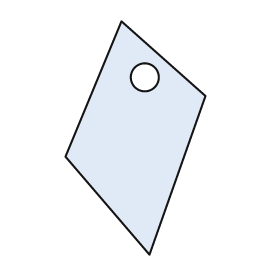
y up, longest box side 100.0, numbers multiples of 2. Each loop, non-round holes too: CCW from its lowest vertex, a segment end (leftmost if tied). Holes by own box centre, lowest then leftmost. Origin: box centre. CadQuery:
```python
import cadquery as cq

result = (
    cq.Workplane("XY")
    .moveTo(6.0, -50.0)
    .lineTo(30.0, 18.0)
    .lineTo(-6.0, 50.0)
    .lineTo(-30.0, -8.0)
    .close()
    .moveTo(4.0, 26.0)
    .circle(6.0)
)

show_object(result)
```